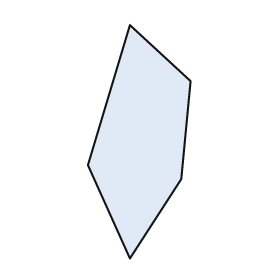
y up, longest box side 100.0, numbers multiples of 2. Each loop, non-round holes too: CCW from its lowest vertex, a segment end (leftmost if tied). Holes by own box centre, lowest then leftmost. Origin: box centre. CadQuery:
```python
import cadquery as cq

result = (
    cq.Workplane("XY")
    .moveTo(-4.0, -50.0)
    .lineTo(18.0, -16.0)
    .lineTo(22.0, 26.0)
    .lineTo(-4.0, 50.0)
    .lineTo(-22.0, -10.0)
    .close()
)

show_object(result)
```